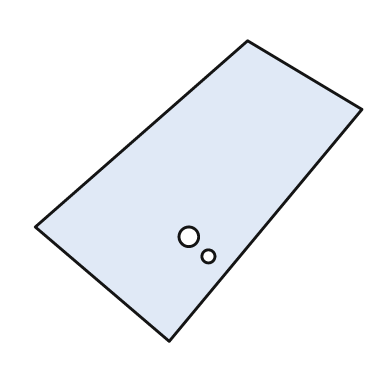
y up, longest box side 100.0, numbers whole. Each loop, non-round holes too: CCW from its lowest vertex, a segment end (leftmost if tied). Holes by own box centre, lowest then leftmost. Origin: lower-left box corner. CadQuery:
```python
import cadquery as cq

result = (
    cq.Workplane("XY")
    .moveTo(41.0, 0.0)
    .lineTo(100.0, 71.0)
    .lineTo(65.0, 92.0)
    .lineTo(0.0, 35.0)
    .close()
    .moveTo(53.0, 26.0)
    .circle(2.0)
    .moveTo(47.0, 32.0)
    .circle(3.0)
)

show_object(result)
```